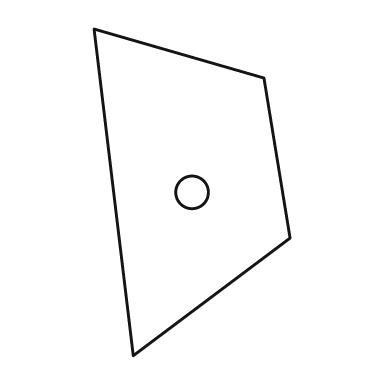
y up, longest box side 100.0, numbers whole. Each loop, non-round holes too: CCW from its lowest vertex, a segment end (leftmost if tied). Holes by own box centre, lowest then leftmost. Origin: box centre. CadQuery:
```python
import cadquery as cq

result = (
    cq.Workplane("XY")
    .moveTo(-18.0, -50.0)
    .lineTo(30.0, -14.0)
    .lineTo(22.0, 35.0)
    .lineTo(-30.0, 50.0)
    .close()
    .moveTo(0.0, 0.0)
    .circle(5.0)
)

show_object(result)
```